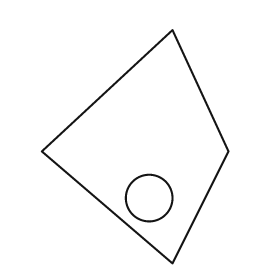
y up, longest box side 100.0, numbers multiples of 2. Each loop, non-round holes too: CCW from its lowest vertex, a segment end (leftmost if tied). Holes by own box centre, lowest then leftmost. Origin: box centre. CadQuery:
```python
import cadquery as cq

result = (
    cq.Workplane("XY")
    .moveTo(16.0, -50.0)
    .lineTo(40.0, -2.0)
    .lineTo(16.0, 50.0)
    .lineTo(-40.0, -2.0)
    .close()
    .moveTo(6.0, -22.0)
    .circle(10.0)
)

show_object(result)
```